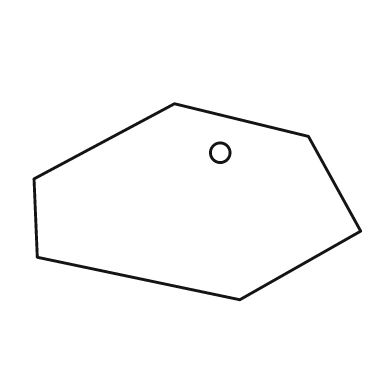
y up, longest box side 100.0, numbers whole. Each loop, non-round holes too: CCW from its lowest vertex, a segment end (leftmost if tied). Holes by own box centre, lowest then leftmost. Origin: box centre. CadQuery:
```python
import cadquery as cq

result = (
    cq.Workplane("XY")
    .moveTo(13.0, -30.0)
    .lineTo(50.0, -9.0)
    .lineTo(34.0, 20.0)
    .lineTo(-7.0, 30.0)
    .lineTo(-50.0, 7.0)
    .lineTo(-49.0, -17.0)
    .close()
    .moveTo(7.0, 15.0)
    .circle(3.0)
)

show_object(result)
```